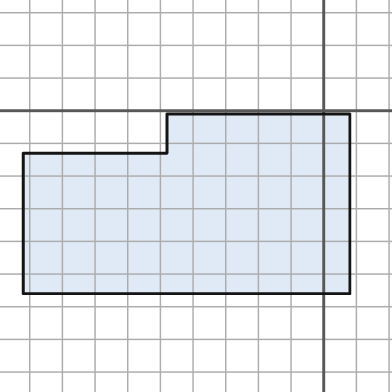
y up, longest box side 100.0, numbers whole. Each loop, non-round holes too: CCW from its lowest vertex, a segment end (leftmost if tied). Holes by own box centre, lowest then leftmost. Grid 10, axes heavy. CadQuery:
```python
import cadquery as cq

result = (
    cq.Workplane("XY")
    .moveTo(-92.0, -56.0)
    .lineTo(8.0, -56.0)
    .lineTo(8.0, -1.0)
    .lineTo(-48.0, -1.0)
    .lineTo(-48.0, -13.0)
    .lineTo(-92.0, -13.0)
    .close()
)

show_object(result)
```